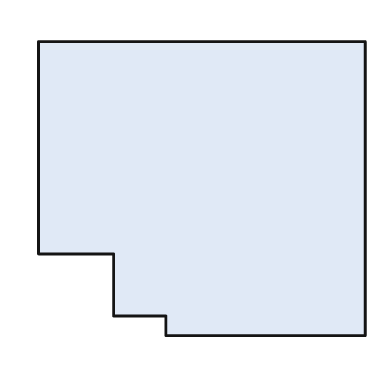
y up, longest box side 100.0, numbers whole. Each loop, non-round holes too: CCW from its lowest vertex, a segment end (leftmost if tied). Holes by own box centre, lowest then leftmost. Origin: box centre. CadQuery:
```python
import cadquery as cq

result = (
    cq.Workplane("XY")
    .moveTo(-11.0, -45.0)
    .lineTo(50.0, -45.0)
    .lineTo(50.0, 45.0)
    .lineTo(-50.0, 45.0)
    .lineTo(-50.0, -20.0)
    .lineTo(-27.0, -20.0)
    .lineTo(-27.0, -39.0)
    .lineTo(-11.0, -39.0)
    .close()
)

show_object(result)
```